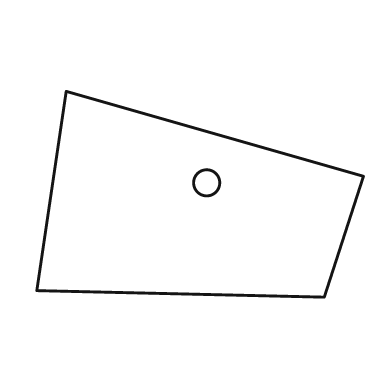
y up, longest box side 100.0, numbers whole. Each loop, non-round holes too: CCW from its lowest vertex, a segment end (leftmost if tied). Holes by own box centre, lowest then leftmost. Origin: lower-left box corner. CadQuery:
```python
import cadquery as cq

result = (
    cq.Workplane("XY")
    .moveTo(88.0, 0.0)
    .lineTo(100.0, 37.0)
    .lineTo(9.0, 63.0)
    .lineTo(0.0, 2.0)
    .close()
    .moveTo(52.0, 35.0)
    .circle(4.0)
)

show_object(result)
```